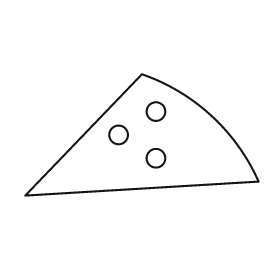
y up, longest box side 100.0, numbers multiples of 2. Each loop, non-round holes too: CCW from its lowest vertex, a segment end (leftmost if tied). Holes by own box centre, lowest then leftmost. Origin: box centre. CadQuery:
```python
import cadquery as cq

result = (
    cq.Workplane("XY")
    .moveTo(-50.0, -26.0)
    .lineTo(50.0, -20.0)
    .threePointArc((30.0, 8.0), (0.0, 26.0))
    .close()
    .moveTo(6.0, -10.0)
    .circle(4.0)
    .moveTo(-10.0, 0.0)
    .circle(4.0)
    .moveTo(6.0, 10.0)
    .circle(4.0)
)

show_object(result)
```